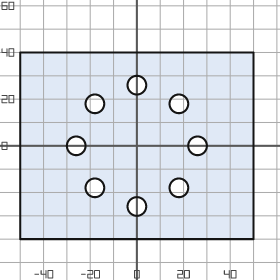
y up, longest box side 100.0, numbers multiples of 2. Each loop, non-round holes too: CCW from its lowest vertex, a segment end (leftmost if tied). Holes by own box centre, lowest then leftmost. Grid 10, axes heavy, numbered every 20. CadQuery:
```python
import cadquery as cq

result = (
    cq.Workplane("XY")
    .moveTo(-50.0, -40.0)
    .lineTo(50.0, -40.0)
    .lineTo(50.0, 40.0)
    .lineTo(-50.0, 40.0)
    .close()
    .moveTo(0.0, -26.0)
    .circle(4.0)
    .moveTo(-18.0, -18.0)
    .circle(4.0)
    .moveTo(18.0, -18.0)
    .circle(4.0)
    .moveTo(-26.0, 0.0)
    .circle(4.0)
    .moveTo(26.0, 0.0)
    .circle(4.0)
    .moveTo(-18.0, 18.0)
    .circle(4.0)
    .moveTo(18.0, 18.0)
    .circle(4.0)
    .moveTo(0.0, 26.0)
    .circle(4.0)
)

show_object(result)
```